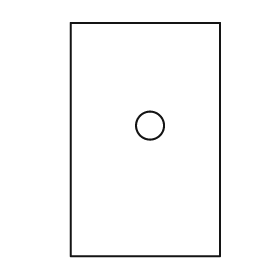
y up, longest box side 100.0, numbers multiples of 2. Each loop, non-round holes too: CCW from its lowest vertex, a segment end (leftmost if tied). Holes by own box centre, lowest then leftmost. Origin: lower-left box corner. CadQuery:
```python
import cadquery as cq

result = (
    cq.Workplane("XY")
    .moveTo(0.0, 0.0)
    .lineTo(64.0, 0.0)
    .lineTo(64.0, 100.0)
    .lineTo(0.0, 100.0)
    .close()
    .moveTo(34.0, 56.0)
    .circle(6.0)
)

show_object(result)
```